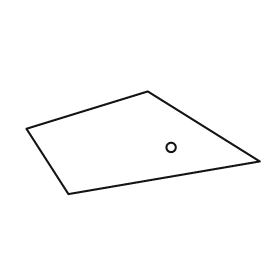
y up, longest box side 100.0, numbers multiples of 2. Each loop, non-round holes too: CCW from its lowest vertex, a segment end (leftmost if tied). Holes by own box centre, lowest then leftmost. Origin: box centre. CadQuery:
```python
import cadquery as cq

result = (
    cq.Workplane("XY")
    .moveTo(-32.0, -22.0)
    .lineTo(50.0, -8.0)
    .lineTo(2.0, 22.0)
    .lineTo(-50.0, 6.0)
    .close()
    .moveTo(12.0, -2.0)
    .circle(2.0)
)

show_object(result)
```